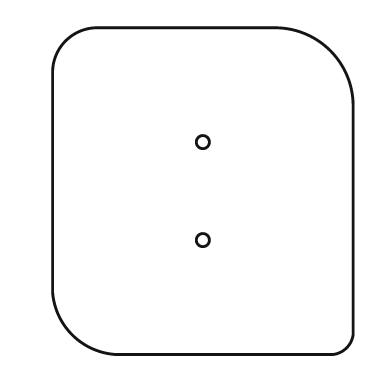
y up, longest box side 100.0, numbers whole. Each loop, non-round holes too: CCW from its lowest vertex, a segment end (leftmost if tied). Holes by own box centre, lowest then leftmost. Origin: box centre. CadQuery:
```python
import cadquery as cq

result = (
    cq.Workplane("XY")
    .moveTo(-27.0, -50.0)
    .lineTo(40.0, -50.0)
    .threePointArc((44.0, -48.0), (46.0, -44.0))
    .lineTo(46.0, 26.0)
    .threePointArc((39.0, 43.0), (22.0, 50.0))
    .lineTo(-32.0, 50.0)
    .threePointArc((-42.0, 46.0), (-46.0, 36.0))
    .lineTo(-46.0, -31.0)
    .threePointArc((-40.0, -44.0), (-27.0, -50.0))
    .close()
    .moveTo(0.0, -15.0)
    .circle(2.0)
    .moveTo(0.0, 15.0)
    .circle(2.0)
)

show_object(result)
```